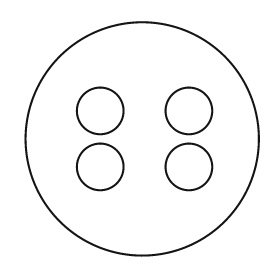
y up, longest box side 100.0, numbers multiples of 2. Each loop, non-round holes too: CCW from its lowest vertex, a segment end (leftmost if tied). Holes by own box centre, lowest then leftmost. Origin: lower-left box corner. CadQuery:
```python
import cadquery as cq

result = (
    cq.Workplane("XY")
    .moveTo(50.0, 50.0)
    .circle(50.0)
    .moveTo(32.0, 38.0)
    .circle(10.0)
    .moveTo(70.0, 38.0)
    .circle(10.0)
    .moveTo(32.0, 62.0)
    .circle(10.0)
    .moveTo(70.0, 62.0)
    .circle(10.0)
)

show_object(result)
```